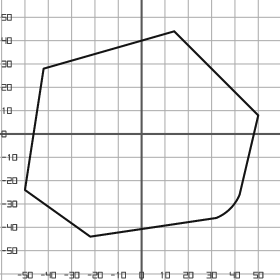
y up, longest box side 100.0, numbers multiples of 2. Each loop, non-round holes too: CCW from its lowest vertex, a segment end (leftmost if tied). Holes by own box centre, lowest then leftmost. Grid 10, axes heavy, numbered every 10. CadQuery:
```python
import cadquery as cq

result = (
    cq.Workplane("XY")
    .moveTo(-22.0, -44.0)
    .lineTo(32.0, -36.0)
    .threePointArc((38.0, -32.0), (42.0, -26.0))
    .lineTo(50.0, 8.0)
    .lineTo(14.0, 44.0)
    .lineTo(-42.0, 28.0)
    .lineTo(-50.0, -24.0)
    .close()
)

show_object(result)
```